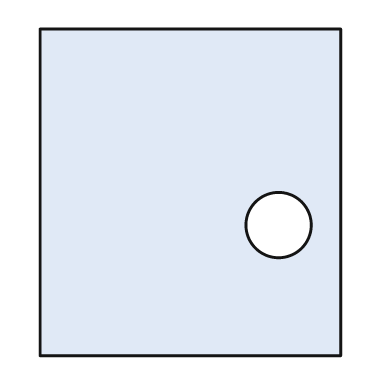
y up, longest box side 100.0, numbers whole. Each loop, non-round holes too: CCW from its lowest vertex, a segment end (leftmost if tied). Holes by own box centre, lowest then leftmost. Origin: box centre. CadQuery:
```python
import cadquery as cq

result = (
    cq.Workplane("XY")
    .moveTo(-46.0, -50.0)
    .lineTo(46.0, -50.0)
    .lineTo(46.0, 50.0)
    .lineTo(-46.0, 50.0)
    .close()
    .moveTo(27.0, -10.0)
    .circle(10.0)
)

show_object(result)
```